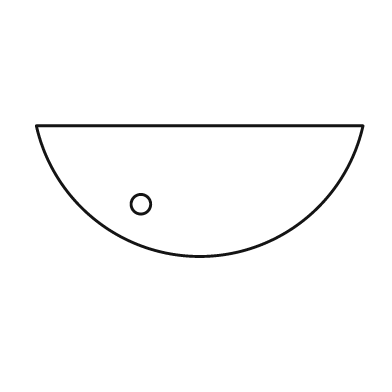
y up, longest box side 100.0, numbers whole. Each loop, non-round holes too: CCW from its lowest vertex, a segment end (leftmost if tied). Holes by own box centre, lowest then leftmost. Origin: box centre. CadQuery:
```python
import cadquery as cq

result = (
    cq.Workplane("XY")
    .moveTo(-50.0, 20.0)
    .threePointArc((0.0, -20.0), (50.0, 20.0))
    .close()
    .moveTo(-18.0, -4.0)
    .circle(3.0)
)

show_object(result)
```